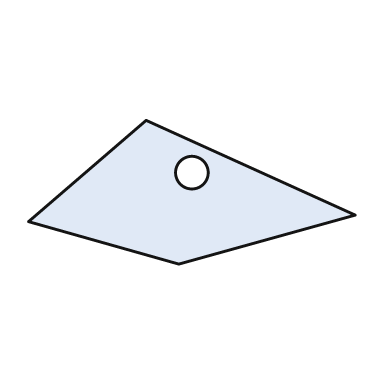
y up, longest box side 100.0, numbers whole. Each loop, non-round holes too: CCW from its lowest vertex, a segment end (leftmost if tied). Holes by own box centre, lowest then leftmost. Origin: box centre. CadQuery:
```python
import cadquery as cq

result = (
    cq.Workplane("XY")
    .moveTo(-4.0, -22.0)
    .lineTo(50.0, -7.0)
    .lineTo(-14.0, 22.0)
    .lineTo(-50.0, -9.0)
    .close()
    .moveTo(0.0, 6.0)
    .circle(5.0)
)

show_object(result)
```